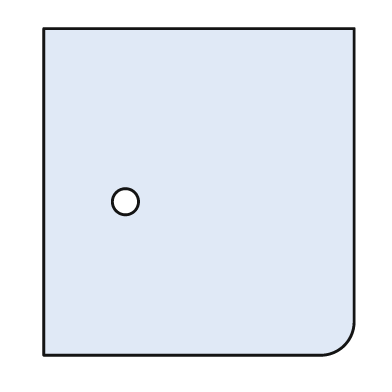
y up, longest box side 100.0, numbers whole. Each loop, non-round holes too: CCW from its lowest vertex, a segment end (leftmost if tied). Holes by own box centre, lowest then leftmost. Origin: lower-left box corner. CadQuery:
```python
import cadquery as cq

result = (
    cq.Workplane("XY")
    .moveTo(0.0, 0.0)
    .lineTo(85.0, 0.0)
    .threePointArc((92.0, 3.0), (95.0, 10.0))
    .lineTo(95.0, 100.0)
    .lineTo(0.0, 100.0)
    .close()
    .moveTo(25.0, 47.0)
    .circle(4.0)
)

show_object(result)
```